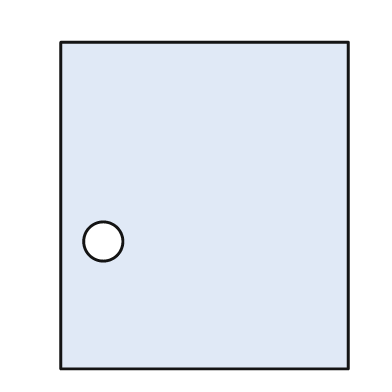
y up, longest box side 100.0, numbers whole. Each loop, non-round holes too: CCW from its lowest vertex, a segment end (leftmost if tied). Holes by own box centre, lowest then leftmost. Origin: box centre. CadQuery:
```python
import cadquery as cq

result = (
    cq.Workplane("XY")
    .moveTo(-44.0, -50.0)
    .lineTo(44.0, -50.0)
    .lineTo(44.0, 50.0)
    .lineTo(-44.0, 50.0)
    .close()
    .moveTo(-31.0, -11.0)
    .circle(6.0)
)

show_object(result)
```